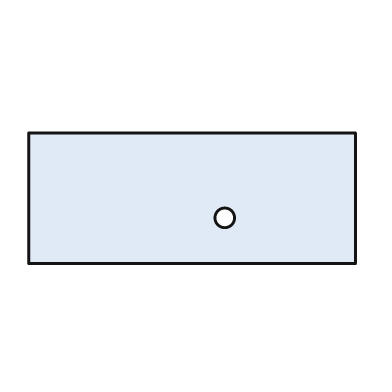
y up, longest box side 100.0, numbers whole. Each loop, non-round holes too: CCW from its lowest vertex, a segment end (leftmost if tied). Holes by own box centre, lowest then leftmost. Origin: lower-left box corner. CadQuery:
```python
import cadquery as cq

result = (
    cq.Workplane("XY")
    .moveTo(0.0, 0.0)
    .lineTo(100.0, 0.0)
    .lineTo(100.0, 40.0)
    .lineTo(0.0, 40.0)
    .close()
    .moveTo(60.0, 14.0)
    .circle(3.0)
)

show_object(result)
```